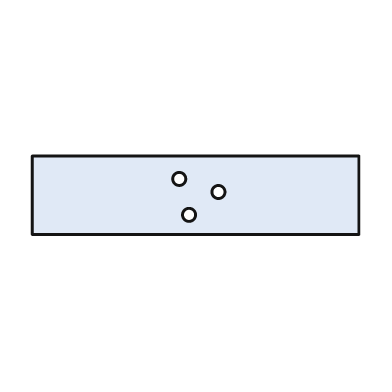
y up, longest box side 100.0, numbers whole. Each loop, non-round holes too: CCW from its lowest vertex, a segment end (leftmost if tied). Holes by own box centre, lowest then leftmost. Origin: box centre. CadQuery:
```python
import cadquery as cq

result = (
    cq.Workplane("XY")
    .moveTo(-50.0, -12.0)
    .lineTo(50.0, -12.0)
    .lineTo(50.0, 12.0)
    .lineTo(-50.0, 12.0)
    .close()
    .moveTo(-2.0, -6.0)
    .circle(2.0)
    .moveTo(7.0, 1.0)
    .circle(2.0)
    .moveTo(-5.0, 5.0)
    .circle(2.0)
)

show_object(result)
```